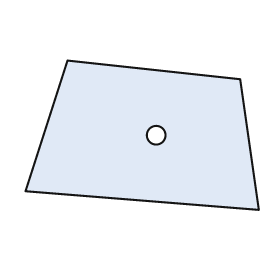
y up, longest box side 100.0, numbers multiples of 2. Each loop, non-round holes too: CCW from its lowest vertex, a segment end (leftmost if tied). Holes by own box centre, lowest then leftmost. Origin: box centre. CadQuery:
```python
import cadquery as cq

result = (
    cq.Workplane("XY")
    .moveTo(50.0, -32.0)
    .lineTo(42.0, 24.0)
    .lineTo(-32.0, 32.0)
    .lineTo(-50.0, -24.0)
    .close()
    .moveTo(6.0, 0.0)
    .circle(4.0)
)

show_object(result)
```